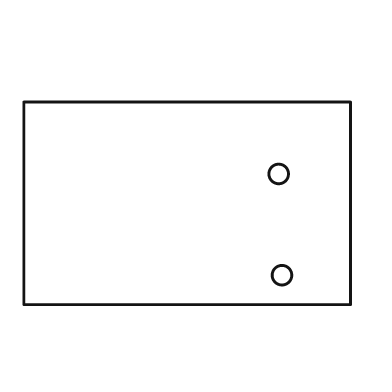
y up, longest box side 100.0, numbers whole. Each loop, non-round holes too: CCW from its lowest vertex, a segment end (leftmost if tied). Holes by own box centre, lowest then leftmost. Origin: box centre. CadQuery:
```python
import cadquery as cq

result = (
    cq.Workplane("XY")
    .moveTo(-50.0, -31.0)
    .lineTo(50.0, -31.0)
    .lineTo(50.0, 31.0)
    .lineTo(-50.0, 31.0)
    .close()
    .moveTo(29.0, -22.0)
    .circle(3.0)
    .moveTo(28.0, 9.0)
    .circle(3.0)
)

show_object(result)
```